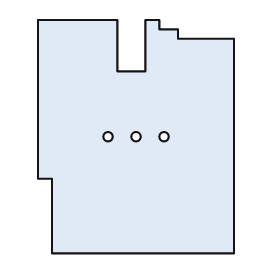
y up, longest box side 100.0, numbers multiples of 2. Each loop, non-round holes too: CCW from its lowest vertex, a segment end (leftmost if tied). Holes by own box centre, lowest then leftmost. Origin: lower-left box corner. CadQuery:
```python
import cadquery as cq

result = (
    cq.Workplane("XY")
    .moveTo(6.0, 0.0)
    .lineTo(84.0, 0.0)
    .lineTo(84.0, 92.0)
    .lineTo(60.0, 92.0)
    .lineTo(60.0, 96.0)
    .lineTo(52.0, 96.0)
    .lineTo(52.0, 100.0)
    .lineTo(46.0, 100.0)
    .lineTo(46.0, 78.0)
    .lineTo(34.0, 78.0)
    .lineTo(34.0, 100.0)
    .lineTo(0.0, 100.0)
    .lineTo(0.0, 32.0)
    .lineTo(6.0, 32.0)
    .close()
    .moveTo(30.0, 50.0)
    .circle(2.0)
    .moveTo(42.0, 50.0)
    .circle(2.0)
    .moveTo(54.0, 50.0)
    .circle(2.0)
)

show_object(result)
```